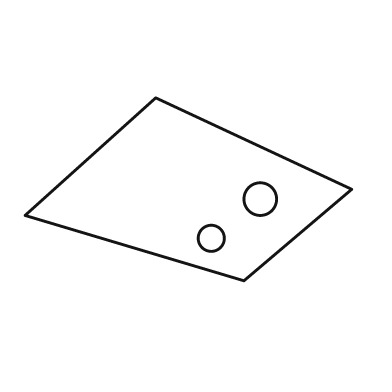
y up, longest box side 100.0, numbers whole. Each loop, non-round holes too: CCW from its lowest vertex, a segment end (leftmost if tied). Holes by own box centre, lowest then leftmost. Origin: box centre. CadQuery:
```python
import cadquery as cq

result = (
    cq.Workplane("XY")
    .moveTo(17.0, -28.0)
    .lineTo(50.0, 0.0)
    .lineTo(-10.0, 28.0)
    .lineTo(-50.0, -8.0)
    .close()
    .moveTo(7.0, -15.0)
    .circle(4.0)
    .moveTo(22.0, -3.0)
    .circle(5.0)
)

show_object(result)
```